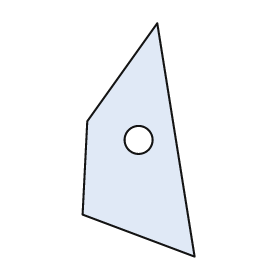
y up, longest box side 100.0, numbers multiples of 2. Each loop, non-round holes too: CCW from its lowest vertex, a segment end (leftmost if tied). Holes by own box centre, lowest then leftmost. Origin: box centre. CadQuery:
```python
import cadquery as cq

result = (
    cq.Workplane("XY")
    .moveTo(24.0, -50.0)
    .lineTo(8.0, 50.0)
    .lineTo(-22.0, 8.0)
    .lineTo(-24.0, -32.0)
    .close()
    .moveTo(0.0, 0.0)
    .circle(6.0)
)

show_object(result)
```